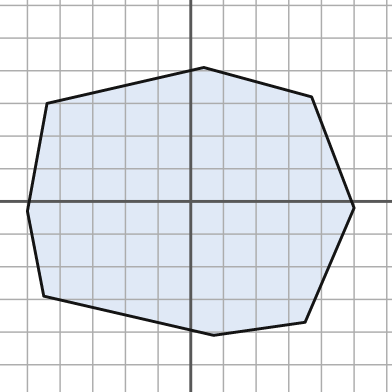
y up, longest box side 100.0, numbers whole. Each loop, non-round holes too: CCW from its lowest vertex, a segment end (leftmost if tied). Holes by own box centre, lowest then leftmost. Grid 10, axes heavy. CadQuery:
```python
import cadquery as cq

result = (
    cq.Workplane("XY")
    .moveTo(7.0, -41.0)
    .lineTo(35.0, -37.0)
    .lineTo(50.0, -2.0)
    .lineTo(37.0, 32.0)
    .lineTo(4.0, 41.0)
    .lineTo(-44.0, 30.0)
    .lineTo(-50.0, -3.0)
    .lineTo(-45.0, -29.0)
    .close()
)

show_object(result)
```